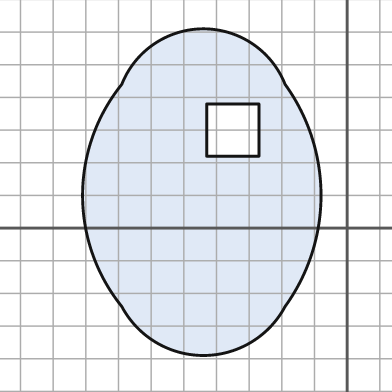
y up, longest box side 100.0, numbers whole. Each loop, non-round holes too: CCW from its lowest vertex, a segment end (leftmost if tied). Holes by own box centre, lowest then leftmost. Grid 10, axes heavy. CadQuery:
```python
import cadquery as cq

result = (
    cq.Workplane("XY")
    .moveTo(-69.0, -24.0)
    .threePointArc((-44.0, -39.0), (-19.0, -24.0))
    .threePointArc((-8.0, 10.0), (-19.0, 44.0))
    .threePointArc((-44.0, 61.0), (-69.0, 44.0))
    .threePointArc((-81.0, 10.0), (-69.0, -24.0))
    .close()
    .moveTo(-43.0, 22.0)
    .lineTo(-27.0, 22.0)
    .lineTo(-27.0, 38.0)
    .lineTo(-43.0, 38.0)
    .close()
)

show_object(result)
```